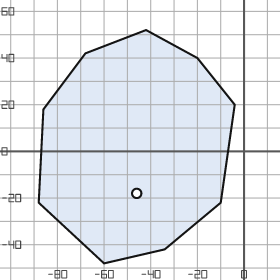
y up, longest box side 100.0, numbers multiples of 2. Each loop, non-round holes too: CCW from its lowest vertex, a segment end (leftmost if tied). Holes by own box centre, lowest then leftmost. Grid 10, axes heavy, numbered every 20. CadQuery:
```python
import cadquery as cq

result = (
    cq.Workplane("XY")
    .moveTo(-60.0, -48.0)
    .lineTo(-34.0, -42.0)
    .lineTo(-10.0, -22.0)
    .lineTo(-4.0, 20.0)
    .lineTo(-20.0, 40.0)
    .lineTo(-42.0, 52.0)
    .lineTo(-68.0, 42.0)
    .lineTo(-86.0, 18.0)
    .lineTo(-88.0, -22.0)
    .close()
    .moveTo(-46.0, -18.0)
    .circle(2.0)
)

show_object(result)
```